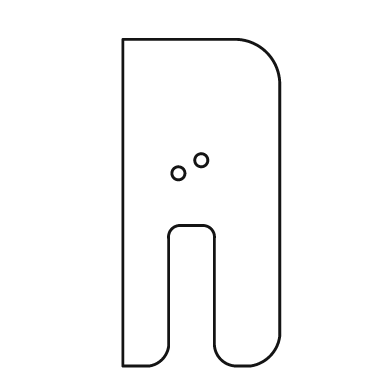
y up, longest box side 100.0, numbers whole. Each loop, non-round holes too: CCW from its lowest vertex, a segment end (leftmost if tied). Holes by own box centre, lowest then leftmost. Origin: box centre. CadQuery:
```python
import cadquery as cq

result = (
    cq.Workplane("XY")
    .moveTo(-24.0, -50.0)
    .lineTo(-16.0, -50.0)
    .threePointArc((-12.0, -48.0), (-10.0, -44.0))
    .lineTo(-10.0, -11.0)
    .threePointArc((-9.0, -8.0), (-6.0, -7.0))
    .lineTo(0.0, -7.0)
    .threePointArc((3.0, -8.0), (4.0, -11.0))
    .lineTo(4.0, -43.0)
    .threePointArc((6.0, -48.0), (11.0, -50.0))
    .lineTo(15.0, -50.0)
    .threePointArc((21.0, -47.0), (24.0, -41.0))
    .lineTo(24.0, 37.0)
    .threePointArc((20.0, 46.0), (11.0, 50.0))
    .lineTo(-24.0, 50.0)
    .close()
    .moveTo(-7.0, 9.0)
    .circle(2.0)
    .moveTo(0.0, 13.0)
    .circle(2.0)
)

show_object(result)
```